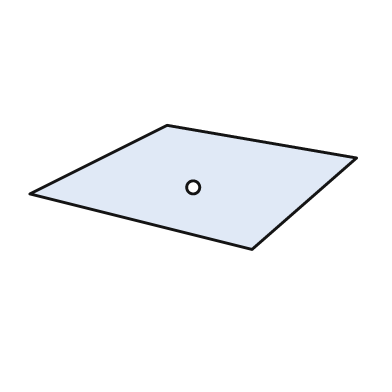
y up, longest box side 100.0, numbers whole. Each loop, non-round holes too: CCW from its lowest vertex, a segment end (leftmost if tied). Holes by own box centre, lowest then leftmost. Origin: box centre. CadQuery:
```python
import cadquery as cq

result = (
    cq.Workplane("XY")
    .moveTo(18.0, -19.0)
    .lineTo(50.0, 9.0)
    .lineTo(-8.0, 19.0)
    .lineTo(-50.0, -2.0)
    .close()
    .moveTo(0.0, 0.0)
    .circle(2.0)
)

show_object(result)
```